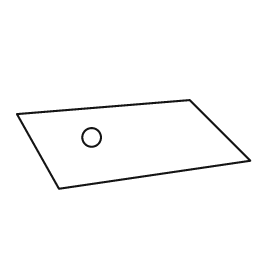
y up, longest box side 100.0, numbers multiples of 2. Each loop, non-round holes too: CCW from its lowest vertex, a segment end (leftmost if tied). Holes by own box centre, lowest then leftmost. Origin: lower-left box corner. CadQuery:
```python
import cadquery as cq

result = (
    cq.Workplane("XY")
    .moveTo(18.0, 0.0)
    .lineTo(100.0, 12.0)
    .lineTo(74.0, 38.0)
    .lineTo(0.0, 32.0)
    .close()
    .moveTo(32.0, 22.0)
    .circle(4.0)
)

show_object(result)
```